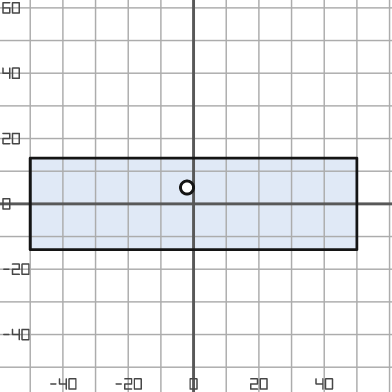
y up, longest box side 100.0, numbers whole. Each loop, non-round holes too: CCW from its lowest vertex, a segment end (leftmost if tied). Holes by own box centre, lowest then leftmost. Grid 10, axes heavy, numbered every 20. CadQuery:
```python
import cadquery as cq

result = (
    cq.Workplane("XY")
    .moveTo(-50.0, -14.0)
    .lineTo(50.0, -14.0)
    .lineTo(50.0, 14.0)
    .lineTo(-50.0, 14.0)
    .close()
    .moveTo(-2.0, 5.0)
    .circle(2.0)
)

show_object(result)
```